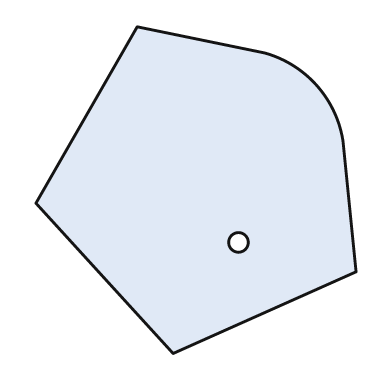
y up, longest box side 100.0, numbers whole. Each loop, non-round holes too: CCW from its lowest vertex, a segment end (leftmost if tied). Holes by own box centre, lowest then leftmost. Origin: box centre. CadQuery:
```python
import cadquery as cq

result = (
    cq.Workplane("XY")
    .moveTo(-7.0, -50.0)
    .lineTo(49.0, -25.0)
    .lineTo(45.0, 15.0)
    .threePointArc((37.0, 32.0), (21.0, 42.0))
    .lineTo(-18.0, 50.0)
    .lineTo(-49.0, -4.0)
    .close()
    .moveTo(13.0, -16.0)
    .circle(3.0)
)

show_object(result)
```